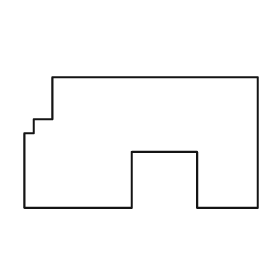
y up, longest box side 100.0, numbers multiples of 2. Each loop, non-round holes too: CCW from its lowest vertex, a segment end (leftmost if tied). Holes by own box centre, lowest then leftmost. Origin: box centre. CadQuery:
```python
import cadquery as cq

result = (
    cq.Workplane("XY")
    .moveTo(-50.0, -28.0)
    .lineTo(-4.0, -28.0)
    .lineTo(-4.0, -4.0)
    .lineTo(24.0, -4.0)
    .lineTo(24.0, -28.0)
    .lineTo(50.0, -28.0)
    .lineTo(50.0, 28.0)
    .lineTo(-38.0, 28.0)
    .lineTo(-38.0, 10.0)
    .lineTo(-46.0, 10.0)
    .lineTo(-46.0, 4.0)
    .lineTo(-50.0, 4.0)
    .close()
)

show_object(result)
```